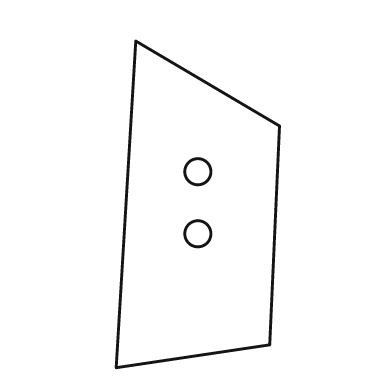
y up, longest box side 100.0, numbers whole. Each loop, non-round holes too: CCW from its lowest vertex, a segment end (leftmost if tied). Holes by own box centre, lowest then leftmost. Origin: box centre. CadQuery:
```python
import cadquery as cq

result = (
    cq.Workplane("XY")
    .moveTo(-25.0, -50.0)
    .lineTo(22.0, -43.0)
    .lineTo(25.0, 24.0)
    .lineTo(-19.0, 50.0)
    .close()
    .moveTo(0.0, -9.0)
    .circle(4.0)
    .moveTo(0.0, 10.0)
    .circle(4.0)
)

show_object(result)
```